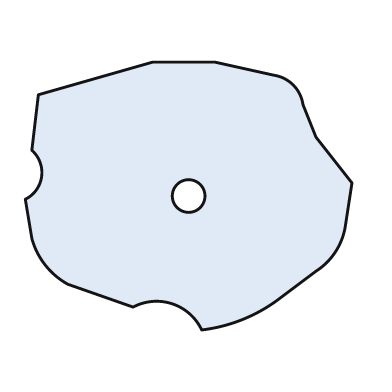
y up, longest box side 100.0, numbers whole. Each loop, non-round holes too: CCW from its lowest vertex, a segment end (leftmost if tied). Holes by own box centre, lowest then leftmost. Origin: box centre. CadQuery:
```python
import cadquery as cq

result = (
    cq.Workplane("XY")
    .moveTo(4.0, -41.0)
    .threePointArc((16.0, -38.0), (27.0, -32.0))
    .lineTo(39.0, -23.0)
    .threePointArc((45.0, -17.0), (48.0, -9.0))
    .lineTo(50.0, 4.0)
    .lineTo(39.0, 18.0)
    .lineTo(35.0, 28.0)
    .threePointArc((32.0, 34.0), (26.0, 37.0))
    .lineTo(8.0, 41.0)
    .lineTo(-11.0, 41.0)
    .lineTo(-46.0, 31.0)
    .lineTo(-48.0, 14.0)
    .threePointArc((-45.0, 6.0), (-50.0, -1.0))
    .lineTo(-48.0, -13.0)
    .threePointArc((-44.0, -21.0), (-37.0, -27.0))
    .lineTo(-17.0, -34.0)
    .threePointArc((-5.0, -33.0), (4.0, -41.0))
    .close()
    .moveTo(0.0, 0.0)
    .circle(5.0)
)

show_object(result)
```